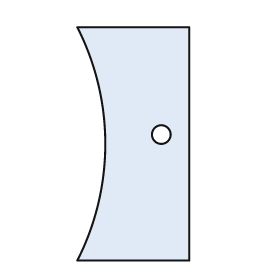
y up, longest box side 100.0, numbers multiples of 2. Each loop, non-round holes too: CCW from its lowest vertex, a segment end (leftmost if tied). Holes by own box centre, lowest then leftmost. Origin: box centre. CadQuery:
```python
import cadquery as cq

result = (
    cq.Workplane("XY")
    .moveTo(-24.0, -50.0)
    .lineTo(24.0, -50.0)
    .lineTo(24.0, 50.0)
    .lineTo(-24.0, 50.0)
    .threePointArc((-12.0, 0.0), (-24.0, -50.0))
    .close()
    .moveTo(12.0, 4.0)
    .circle(4.0)
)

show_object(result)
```